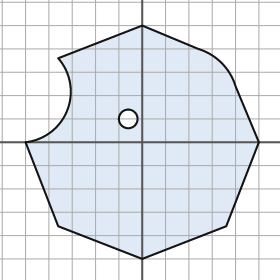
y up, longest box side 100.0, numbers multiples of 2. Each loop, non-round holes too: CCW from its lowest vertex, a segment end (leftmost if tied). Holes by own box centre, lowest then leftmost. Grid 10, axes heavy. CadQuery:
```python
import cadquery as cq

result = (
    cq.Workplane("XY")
    .moveTo(0.0, -50.0)
    .lineTo(36.0, -36.0)
    .lineTo(50.0, 0.0)
    .lineTo(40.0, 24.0)
    .threePointArc((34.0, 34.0), (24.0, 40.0))
    .lineTo(0.0, 50.0)
    .lineTo(-36.0, 36.0)
    .threePointArc((-32.0, 14.0), (-50.0, 0.0))
    .lineTo(-36.0, -36.0)
    .close()
    .moveTo(-6.0, 10.0)
    .circle(4.0)
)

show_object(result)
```